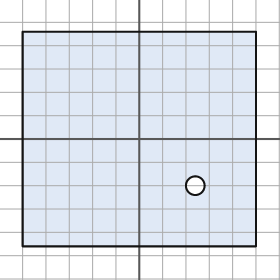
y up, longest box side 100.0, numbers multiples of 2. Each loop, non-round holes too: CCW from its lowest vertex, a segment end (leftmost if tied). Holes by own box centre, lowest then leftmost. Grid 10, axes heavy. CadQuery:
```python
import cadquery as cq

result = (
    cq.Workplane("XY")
    .moveTo(-50.0, -46.0)
    .lineTo(50.0, -46.0)
    .lineTo(50.0, 46.0)
    .lineTo(-50.0, 46.0)
    .close()
    .moveTo(24.0, -20.0)
    .circle(4.0)
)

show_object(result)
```